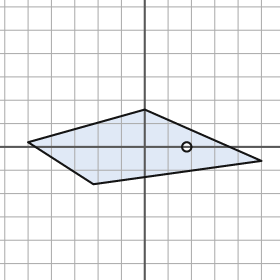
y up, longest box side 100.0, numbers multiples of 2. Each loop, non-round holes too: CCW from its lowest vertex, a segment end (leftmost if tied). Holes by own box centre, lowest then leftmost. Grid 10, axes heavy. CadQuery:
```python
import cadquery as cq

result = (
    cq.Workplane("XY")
    .moveTo(-22.0, -16.0)
    .lineTo(50.0, -6.0)
    .lineTo(0.0, 16.0)
    .lineTo(-50.0, 2.0)
    .close()
    .moveTo(18.0, 0.0)
    .circle(2.0)
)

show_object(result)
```